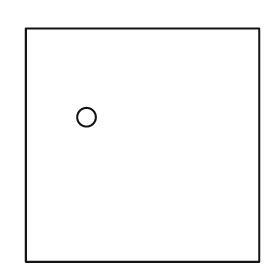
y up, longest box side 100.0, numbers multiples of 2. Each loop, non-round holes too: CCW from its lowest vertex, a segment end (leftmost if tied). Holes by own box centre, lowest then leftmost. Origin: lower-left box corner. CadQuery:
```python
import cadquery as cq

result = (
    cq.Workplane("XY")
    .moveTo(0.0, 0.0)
    .lineTo(100.0, 0.0)
    .lineTo(100.0, 100.0)
    .lineTo(0.0, 100.0)
    .close()
    .moveTo(26.0, 62.0)
    .circle(4.0)
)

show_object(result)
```